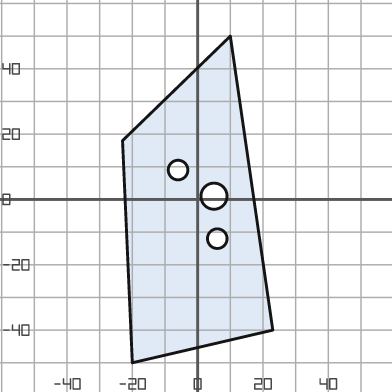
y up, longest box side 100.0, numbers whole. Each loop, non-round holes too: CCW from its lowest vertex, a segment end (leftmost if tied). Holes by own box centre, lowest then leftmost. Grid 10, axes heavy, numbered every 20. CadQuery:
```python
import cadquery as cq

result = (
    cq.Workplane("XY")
    .moveTo(-20.0, -50.0)
    .lineTo(23.0, -40.0)
    .lineTo(10.0, 50.0)
    .lineTo(-23.0, 18.0)
    .close()
    .moveTo(6.0, -12.0)
    .circle(3.0)
    .moveTo(5.0, 1.0)
    .circle(4.0)
    .moveTo(-6.0, 9.0)
    .circle(3.0)
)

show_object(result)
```